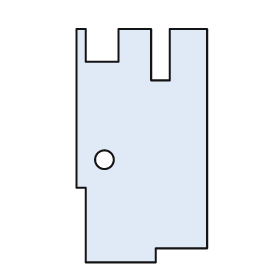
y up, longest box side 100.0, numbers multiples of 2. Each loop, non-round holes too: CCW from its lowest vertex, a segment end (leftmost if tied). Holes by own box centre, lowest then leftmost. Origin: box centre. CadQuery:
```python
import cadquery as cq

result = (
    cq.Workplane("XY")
    .moveTo(-24.0, -50.0)
    .lineTo(6.0, -50.0)
    .lineTo(6.0, -44.0)
    .lineTo(28.0, -44.0)
    .lineTo(28.0, 50.0)
    .lineTo(12.0, 50.0)
    .lineTo(12.0, 28.0)
    .lineTo(4.0, 28.0)
    .lineTo(4.0, 50.0)
    .lineTo(-10.0, 50.0)
    .lineTo(-10.0, 36.0)
    .lineTo(-24.0, 36.0)
    .lineTo(-24.0, 50.0)
    .lineTo(-28.0, 50.0)
    .lineTo(-28.0, -18.0)
    .lineTo(-24.0, -18.0)
    .close()
    .moveTo(-16.0, -6.0)
    .circle(4.0)
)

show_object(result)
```